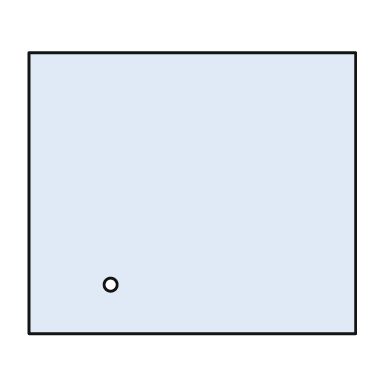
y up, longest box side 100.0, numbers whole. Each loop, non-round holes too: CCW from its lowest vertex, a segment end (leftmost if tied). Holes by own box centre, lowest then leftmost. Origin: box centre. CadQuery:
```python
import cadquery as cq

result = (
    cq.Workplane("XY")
    .moveTo(-50.0, -43.0)
    .lineTo(50.0, -43.0)
    .lineTo(50.0, 43.0)
    .lineTo(-50.0, 43.0)
    .close()
    .moveTo(-25.0, -28.0)
    .circle(2.0)
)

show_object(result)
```